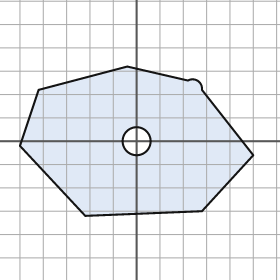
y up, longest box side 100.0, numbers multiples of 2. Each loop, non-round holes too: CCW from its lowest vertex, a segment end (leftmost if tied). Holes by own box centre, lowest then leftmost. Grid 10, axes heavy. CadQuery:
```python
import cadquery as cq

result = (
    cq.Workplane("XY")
    .moveTo(-22.0, -32.0)
    .lineTo(28.0, -30.0)
    .lineTo(50.0, -6.0)
    .lineTo(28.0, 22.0)
    .threePointArc((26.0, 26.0), (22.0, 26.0))
    .lineTo(-4.0, 32.0)
    .lineTo(-42.0, 22.0)
    .lineTo(-50.0, -2.0)
    .close()
    .moveTo(0.0, 0.0)
    .circle(6.0)
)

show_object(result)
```